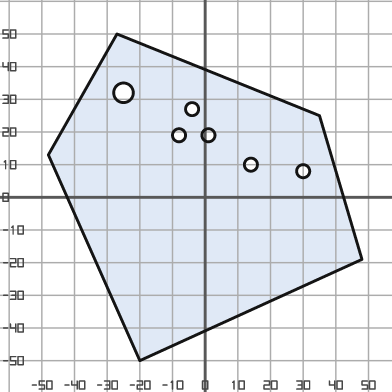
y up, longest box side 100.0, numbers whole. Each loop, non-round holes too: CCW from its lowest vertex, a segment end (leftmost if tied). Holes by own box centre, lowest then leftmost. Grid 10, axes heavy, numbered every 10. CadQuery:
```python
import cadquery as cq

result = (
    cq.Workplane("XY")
    .moveTo(-20.0, -50.0)
    .lineTo(48.0, -19.0)
    .lineTo(35.0, 25.0)
    .lineTo(-27.0, 50.0)
    .lineTo(-48.0, 13.0)
    .close()
    .moveTo(30.0, 8.0)
    .circle(2.0)
    .moveTo(14.0, 10.0)
    .circle(2.0)
    .moveTo(-8.0, 19.0)
    .circle(2.0)
    .moveTo(1.0, 19.0)
    .circle(2.0)
    .moveTo(-4.0, 27.0)
    .circle(2.0)
    .moveTo(-25.0, 32.0)
    .circle(3.0)
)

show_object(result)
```